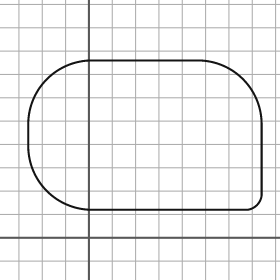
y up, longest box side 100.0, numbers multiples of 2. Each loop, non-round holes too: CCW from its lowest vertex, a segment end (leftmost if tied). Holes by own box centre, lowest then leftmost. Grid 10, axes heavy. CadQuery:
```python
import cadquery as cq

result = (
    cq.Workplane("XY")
    .moveTo(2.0, 12.0)
    .lineTo(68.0, 12.0)
    .threePointArc((72.0, 14.0), (74.0, 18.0))
    .lineTo(74.0, 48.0)
    .threePointArc((66.0, 68.0), (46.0, 76.0))
    .lineTo(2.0, 76.0)
    .threePointArc((-18.0, 68.0), (-26.0, 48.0))
    .lineTo(-26.0, 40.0)
    .threePointArc((-18.0, 20.0), (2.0, 12.0))
    .close()
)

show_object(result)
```